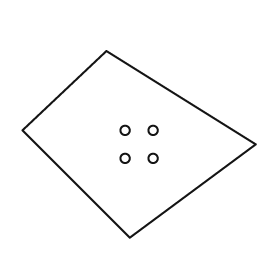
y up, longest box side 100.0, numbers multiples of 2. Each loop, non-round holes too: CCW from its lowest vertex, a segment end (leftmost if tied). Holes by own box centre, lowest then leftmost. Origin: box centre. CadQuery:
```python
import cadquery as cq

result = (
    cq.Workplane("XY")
    .moveTo(-4.0, -40.0)
    .lineTo(50.0, 0.0)
    .lineTo(-14.0, 40.0)
    .lineTo(-50.0, 6.0)
    .close()
    .moveTo(-6.0, -6.0)
    .circle(2.0)
    .moveTo(6.0, -6.0)
    .circle(2.0)
    .moveTo(-6.0, 6.0)
    .circle(2.0)
    .moveTo(6.0, 6.0)
    .circle(2.0)
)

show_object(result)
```